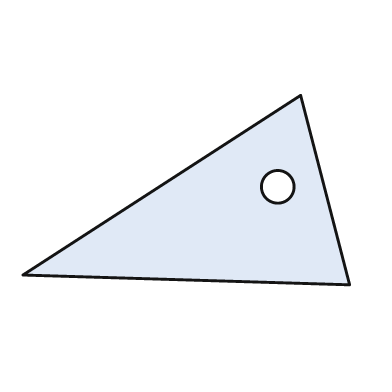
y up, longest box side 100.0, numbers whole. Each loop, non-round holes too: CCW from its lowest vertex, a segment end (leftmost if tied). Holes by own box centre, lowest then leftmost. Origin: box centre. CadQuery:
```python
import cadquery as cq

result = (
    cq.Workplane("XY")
    .moveTo(50.0, -29.0)
    .lineTo(35.0, 29.0)
    .lineTo(-50.0, -26.0)
    .close()
    .moveTo(28.0, 1.0)
    .circle(5.0)
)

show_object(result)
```